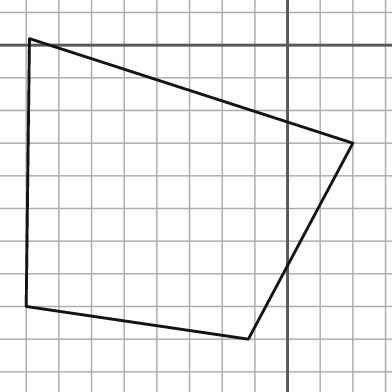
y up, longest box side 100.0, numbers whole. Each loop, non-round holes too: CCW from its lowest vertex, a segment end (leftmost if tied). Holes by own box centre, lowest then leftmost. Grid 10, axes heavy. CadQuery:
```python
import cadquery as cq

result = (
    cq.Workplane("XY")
    .moveTo(-12.0, -90.0)
    .lineTo(20.0, -30.0)
    .lineTo(-79.0, 2.0)
    .lineTo(-80.0, -80.0)
    .close()
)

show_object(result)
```